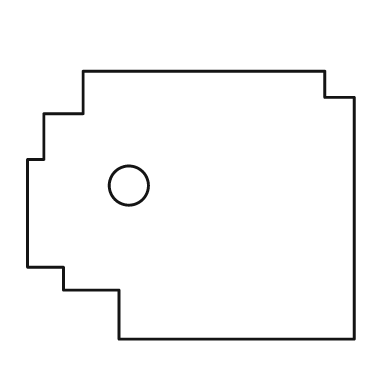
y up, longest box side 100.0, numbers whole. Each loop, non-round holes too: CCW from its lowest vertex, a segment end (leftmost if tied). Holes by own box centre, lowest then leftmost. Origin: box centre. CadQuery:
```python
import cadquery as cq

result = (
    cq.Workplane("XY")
    .moveTo(-22.0, -41.0)
    .lineTo(50.0, -41.0)
    .lineTo(50.0, 33.0)
    .lineTo(41.0, 33.0)
    .lineTo(41.0, 41.0)
    .lineTo(-33.0, 41.0)
    .lineTo(-33.0, 28.0)
    .lineTo(-45.0, 28.0)
    .lineTo(-45.0, 14.0)
    .lineTo(-50.0, 14.0)
    .lineTo(-50.0, -19.0)
    .lineTo(-39.0, -19.0)
    .lineTo(-39.0, -26.0)
    .lineTo(-22.0, -26.0)
    .close()
    .moveTo(-19.0, 6.0)
    .circle(6.0)
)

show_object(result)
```